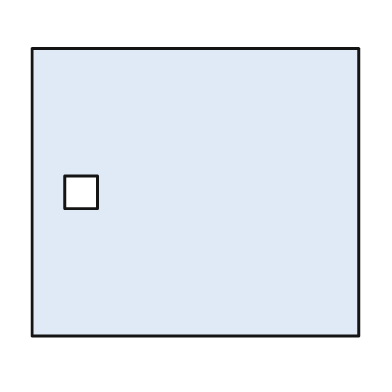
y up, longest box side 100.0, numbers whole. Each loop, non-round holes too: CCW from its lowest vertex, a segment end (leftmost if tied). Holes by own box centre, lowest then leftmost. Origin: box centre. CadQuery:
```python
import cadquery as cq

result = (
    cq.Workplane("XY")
    .moveTo(-50.0, -44.0)
    .lineTo(50.0, -44.0)
    .lineTo(50.0, 44.0)
    .lineTo(-50.0, 44.0)
    .close()
    .moveTo(-40.0, -5.0)
    .lineTo(-30.0, -5.0)
    .lineTo(-30.0, 5.0)
    .lineTo(-40.0, 5.0)
    .close()
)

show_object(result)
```